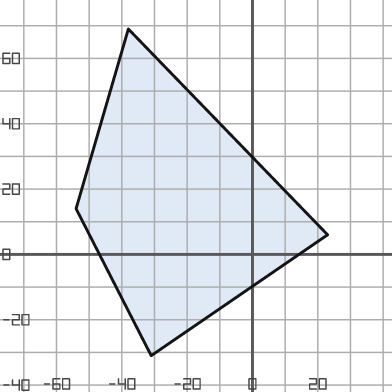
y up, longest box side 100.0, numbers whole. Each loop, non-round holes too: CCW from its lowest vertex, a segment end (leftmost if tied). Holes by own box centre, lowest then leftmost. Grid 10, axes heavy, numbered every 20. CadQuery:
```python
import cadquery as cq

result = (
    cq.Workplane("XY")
    .moveTo(-31.0, -31.0)
    .lineTo(23.0, 6.0)
    .lineTo(-38.0, 69.0)
    .lineTo(-54.0, 14.0)
    .close()
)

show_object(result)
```